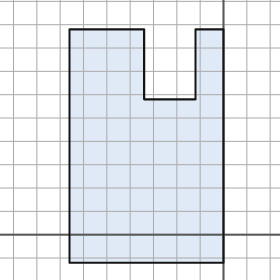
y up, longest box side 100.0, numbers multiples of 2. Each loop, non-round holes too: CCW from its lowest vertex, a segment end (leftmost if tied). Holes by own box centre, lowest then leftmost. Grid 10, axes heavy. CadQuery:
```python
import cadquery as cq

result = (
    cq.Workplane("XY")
    .moveTo(-66.0, -12.0)
    .lineTo(0.0, -12.0)
    .lineTo(0.0, 88.0)
    .lineTo(-12.0, 88.0)
    .lineTo(-12.0, 58.0)
    .lineTo(-34.0, 58.0)
    .lineTo(-34.0, 88.0)
    .lineTo(-66.0, 88.0)
    .close()
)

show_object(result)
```